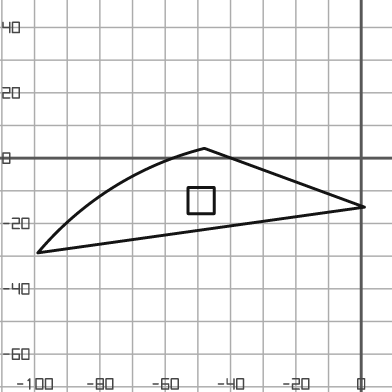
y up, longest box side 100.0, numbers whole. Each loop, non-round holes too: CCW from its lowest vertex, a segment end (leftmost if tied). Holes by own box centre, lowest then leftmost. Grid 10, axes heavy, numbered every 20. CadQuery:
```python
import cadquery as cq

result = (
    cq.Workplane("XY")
    .moveTo(-99.0, -29.0)
    .lineTo(1.0, -15.0)
    .lineTo(-48.0, 3.0)
    .threePointArc((-76.0, -9.0), (-99.0, -29.0))
    .close()
    .moveTo(-53.0, -17.0)
    .lineTo(-45.0, -17.0)
    .lineTo(-45.0, -9.0)
    .lineTo(-53.0, -9.0)
    .close()
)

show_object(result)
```